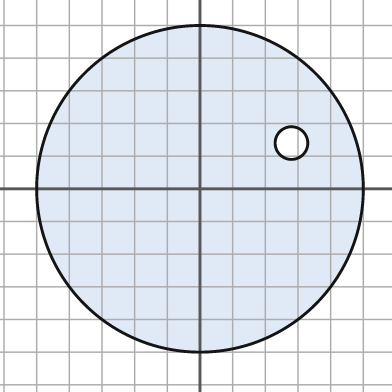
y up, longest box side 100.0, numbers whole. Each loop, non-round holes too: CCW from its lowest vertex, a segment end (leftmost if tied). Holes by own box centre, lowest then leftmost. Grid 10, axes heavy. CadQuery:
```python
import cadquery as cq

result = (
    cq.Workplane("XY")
    .moveTo(0.0, 0.0)
    .circle(50.0)
    .moveTo(28.0, 14.0)
    .circle(5.0)
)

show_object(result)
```